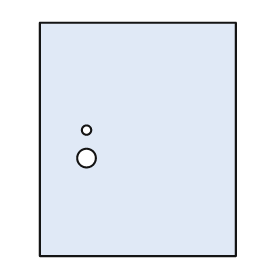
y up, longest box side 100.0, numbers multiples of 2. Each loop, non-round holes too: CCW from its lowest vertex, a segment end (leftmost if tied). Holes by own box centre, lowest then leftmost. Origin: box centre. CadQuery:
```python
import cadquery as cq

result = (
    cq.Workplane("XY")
    .moveTo(-42.0, -50.0)
    .lineTo(42.0, -50.0)
    .lineTo(42.0, 50.0)
    .lineTo(-42.0, 50.0)
    .close()
    .moveTo(-22.0, -8.0)
    .circle(4.0)
    .moveTo(-22.0, 4.0)
    .circle(2.0)
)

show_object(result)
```